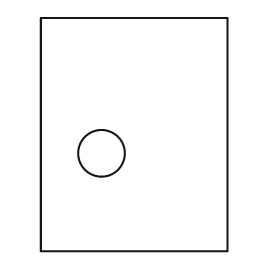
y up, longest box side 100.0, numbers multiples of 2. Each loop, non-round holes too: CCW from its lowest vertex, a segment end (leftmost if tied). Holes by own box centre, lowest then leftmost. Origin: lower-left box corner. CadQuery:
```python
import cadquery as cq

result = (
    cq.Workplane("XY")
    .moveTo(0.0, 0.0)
    .lineTo(80.0, 0.0)
    .lineTo(80.0, 100.0)
    .lineTo(0.0, 100.0)
    .close()
    .moveTo(26.0, 42.0)
    .circle(10.0)
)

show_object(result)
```